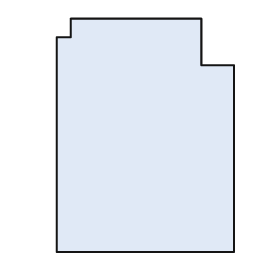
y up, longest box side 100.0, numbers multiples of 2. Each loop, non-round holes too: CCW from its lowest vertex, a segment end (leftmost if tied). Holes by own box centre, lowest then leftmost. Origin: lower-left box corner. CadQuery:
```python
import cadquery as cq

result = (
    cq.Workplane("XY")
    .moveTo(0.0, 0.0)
    .lineTo(76.0, 0.0)
    .lineTo(76.0, 80.0)
    .lineTo(62.0, 80.0)
    .lineTo(62.0, 100.0)
    .lineTo(6.0, 100.0)
    .lineTo(6.0, 92.0)
    .lineTo(0.0, 92.0)
    .close()
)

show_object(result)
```